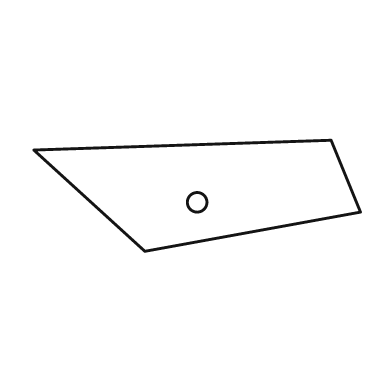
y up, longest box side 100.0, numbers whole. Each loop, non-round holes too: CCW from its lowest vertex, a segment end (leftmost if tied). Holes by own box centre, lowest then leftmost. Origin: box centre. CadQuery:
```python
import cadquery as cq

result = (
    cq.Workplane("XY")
    .moveTo(-16.0, -17.0)
    .lineTo(50.0, -5.0)
    .lineTo(41.0, 17.0)
    .lineTo(-50.0, 14.0)
    .close()
    .moveTo(0.0, -2.0)
    .circle(3.0)
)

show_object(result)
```